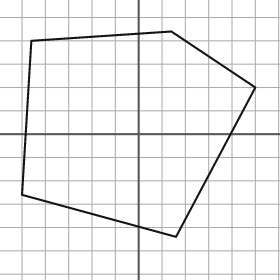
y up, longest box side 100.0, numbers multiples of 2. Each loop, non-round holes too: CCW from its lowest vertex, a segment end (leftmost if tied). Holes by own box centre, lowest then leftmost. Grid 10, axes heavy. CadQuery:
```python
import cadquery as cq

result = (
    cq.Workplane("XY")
    .moveTo(16.0, -44.0)
    .lineTo(50.0, 20.0)
    .lineTo(14.0, 44.0)
    .lineTo(-46.0, 40.0)
    .lineTo(-50.0, -26.0)
    .close()
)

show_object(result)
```